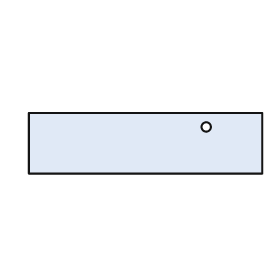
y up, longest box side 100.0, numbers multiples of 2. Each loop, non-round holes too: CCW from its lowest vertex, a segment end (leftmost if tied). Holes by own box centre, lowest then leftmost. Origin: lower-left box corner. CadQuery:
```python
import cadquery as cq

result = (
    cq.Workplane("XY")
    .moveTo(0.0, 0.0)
    .lineTo(100.0, 0.0)
    .lineTo(100.0, 26.0)
    .lineTo(0.0, 26.0)
    .close()
    .moveTo(76.0, 20.0)
    .circle(2.0)
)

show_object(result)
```